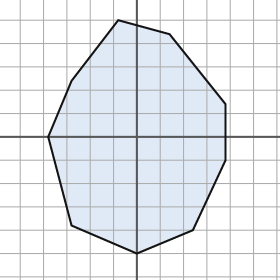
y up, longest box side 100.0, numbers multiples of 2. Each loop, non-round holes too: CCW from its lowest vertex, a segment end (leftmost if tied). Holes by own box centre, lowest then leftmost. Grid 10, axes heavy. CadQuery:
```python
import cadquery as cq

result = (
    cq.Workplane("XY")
    .moveTo(0.0, -50.0)
    .lineTo(24.0, -40.0)
    .lineTo(38.0, -10.0)
    .lineTo(38.0, 14.0)
    .lineTo(14.0, 44.0)
    .lineTo(-8.0, 50.0)
    .lineTo(-28.0, 24.0)
    .lineTo(-38.0, 0.0)
    .lineTo(-28.0, -38.0)
    .close()
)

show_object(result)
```